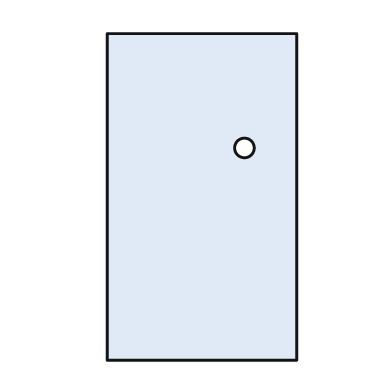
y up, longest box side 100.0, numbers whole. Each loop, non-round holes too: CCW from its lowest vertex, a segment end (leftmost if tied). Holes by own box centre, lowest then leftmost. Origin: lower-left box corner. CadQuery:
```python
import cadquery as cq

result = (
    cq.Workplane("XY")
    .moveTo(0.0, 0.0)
    .lineTo(58.0, 0.0)
    .lineTo(58.0, 100.0)
    .lineTo(0.0, 100.0)
    .close()
    .moveTo(42.0, 65.0)
    .circle(3.0)
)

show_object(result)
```